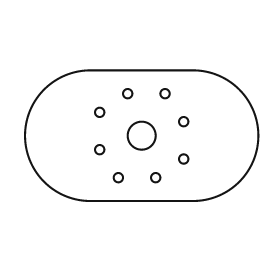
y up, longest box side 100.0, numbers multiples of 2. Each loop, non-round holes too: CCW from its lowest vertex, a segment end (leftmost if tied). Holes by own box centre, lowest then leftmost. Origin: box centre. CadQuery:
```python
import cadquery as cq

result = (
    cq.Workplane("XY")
    .moveTo(-22.0, -28.0)
    .lineTo(22.0, -28.0)
    .threePointArc((50.0, 0.0), (22.0, 28.0))
    .lineTo(-22.0, 28.0)
    .threePointArc((-50.0, 0.0), (-22.0, -28.0))
    .close()
    .moveTo(-10.0, -18.0)
    .circle(2.0)
    .moveTo(6.0, -18.0)
    .circle(2.0)
    .moveTo(18.0, -10.0)
    .circle(2.0)
    .moveTo(-18.0, -6.0)
    .circle(2.0)
    .moveTo(0.0, 0.0)
    .circle(6.0)
    .moveTo(18.0, 6.0)
    .circle(2.0)
    .moveTo(-18.0, 10.0)
    .circle(2.0)
    .moveTo(-6.0, 18.0)
    .circle(2.0)
    .moveTo(10.0, 18.0)
    .circle(2.0)
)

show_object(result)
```